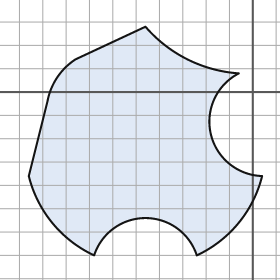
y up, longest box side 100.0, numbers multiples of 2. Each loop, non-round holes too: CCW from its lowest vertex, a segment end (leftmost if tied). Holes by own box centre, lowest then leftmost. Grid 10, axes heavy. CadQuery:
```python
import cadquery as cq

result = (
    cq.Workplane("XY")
    .moveTo(-68.0, -70.0)
    .threePointArc((-46.0, -54.0), (-24.0, -70.0))
    .threePointArc((-6.0, -56.0), (4.0, -36.0))
    .threePointArc((-18.0, -18.0), (-6.0, 8.0))
    .threePointArc((-28.0, 14.0), (-46.0, 28.0))
    .lineTo(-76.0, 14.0)
    .threePointArc((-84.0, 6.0), (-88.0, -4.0))
    .lineTo(-96.0, -36.0)
    .threePointArc((-86.0, -56.0), (-68.0, -70.0))
    .close()
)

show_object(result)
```